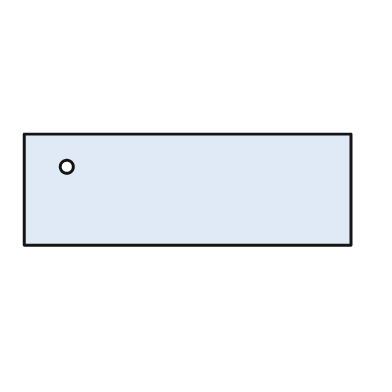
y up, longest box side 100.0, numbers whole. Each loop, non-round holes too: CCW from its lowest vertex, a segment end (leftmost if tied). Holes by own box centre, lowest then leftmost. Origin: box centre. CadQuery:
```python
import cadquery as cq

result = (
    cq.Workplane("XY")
    .moveTo(-50.0, -17.0)
    .lineTo(50.0, -17.0)
    .lineTo(50.0, 17.0)
    .lineTo(-50.0, 17.0)
    .close()
    .moveTo(-37.0, 7.0)
    .circle(2.0)
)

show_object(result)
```